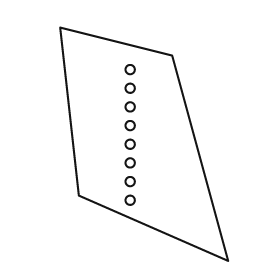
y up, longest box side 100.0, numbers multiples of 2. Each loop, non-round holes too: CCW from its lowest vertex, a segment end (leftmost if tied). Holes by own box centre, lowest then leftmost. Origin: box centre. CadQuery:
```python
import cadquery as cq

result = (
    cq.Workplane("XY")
    .moveTo(36.0, -50.0)
    .lineTo(12.0, 38.0)
    .lineTo(-36.0, 50.0)
    .lineTo(-28.0, -22.0)
    .close()
    .moveTo(-6.0, -24.0)
    .circle(2.0)
    .moveTo(-6.0, -16.0)
    .circle(2.0)
    .moveTo(-6.0, -8.0)
    .circle(2.0)
    .moveTo(-6.0, 0.0)
    .circle(2.0)
    .moveTo(-6.0, 8.0)
    .circle(2.0)
    .moveTo(-6.0, 16.0)
    .circle(2.0)
    .moveTo(-6.0, 24.0)
    .circle(2.0)
    .moveTo(-6.0, 32.0)
    .circle(2.0)
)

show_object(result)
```